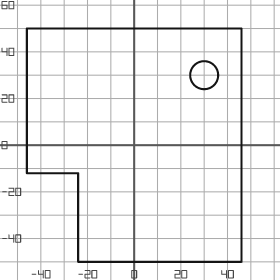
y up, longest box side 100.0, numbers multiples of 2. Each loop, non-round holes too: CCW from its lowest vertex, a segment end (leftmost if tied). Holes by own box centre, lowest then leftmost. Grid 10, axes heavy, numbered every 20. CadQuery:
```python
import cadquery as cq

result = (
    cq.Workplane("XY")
    .moveTo(-24.0, -50.0)
    .lineTo(46.0, -50.0)
    .lineTo(46.0, 50.0)
    .lineTo(-46.0, 50.0)
    .lineTo(-46.0, -12.0)
    .lineTo(-24.0, -12.0)
    .close()
    .moveTo(30.0, 30.0)
    .circle(6.0)
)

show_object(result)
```